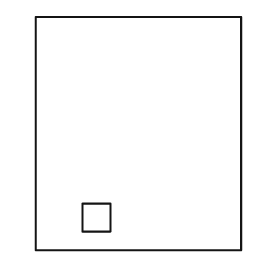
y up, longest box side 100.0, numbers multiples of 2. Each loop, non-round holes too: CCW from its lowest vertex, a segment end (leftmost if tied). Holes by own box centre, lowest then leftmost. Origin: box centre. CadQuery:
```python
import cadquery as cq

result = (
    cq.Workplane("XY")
    .moveTo(-44.0, -50.0)
    .lineTo(44.0, -50.0)
    .lineTo(44.0, 50.0)
    .lineTo(-44.0, 50.0)
    .close()
    .moveTo(-24.0, -42.0)
    .lineTo(-12.0, -42.0)
    .lineTo(-12.0, -30.0)
    .lineTo(-24.0, -30.0)
    .close()
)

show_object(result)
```